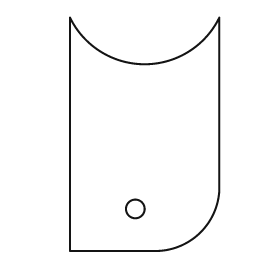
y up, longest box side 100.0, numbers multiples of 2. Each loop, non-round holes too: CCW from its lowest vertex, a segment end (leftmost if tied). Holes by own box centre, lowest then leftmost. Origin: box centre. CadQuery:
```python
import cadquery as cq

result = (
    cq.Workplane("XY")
    .moveTo(-32.0, -50.0)
    .lineTo(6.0, -50.0)
    .threePointArc((24.0, -42.0), (32.0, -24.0))
    .lineTo(32.0, 50.0)
    .threePointArc((0.0, 30.0), (-32.0, 50.0))
    .close()
    .moveTo(-4.0, -32.0)
    .circle(4.0)
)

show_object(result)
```